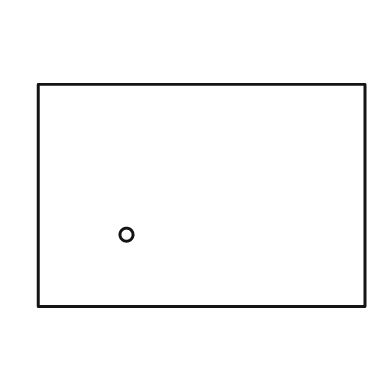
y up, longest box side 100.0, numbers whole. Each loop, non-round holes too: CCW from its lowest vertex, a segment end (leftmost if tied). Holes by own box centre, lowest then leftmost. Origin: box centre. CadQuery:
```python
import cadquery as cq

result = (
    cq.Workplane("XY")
    .moveTo(-50.0, -34.0)
    .lineTo(50.0, -34.0)
    .lineTo(50.0, 34.0)
    .lineTo(-50.0, 34.0)
    .close()
    .moveTo(-23.0, -12.0)
    .circle(2.0)
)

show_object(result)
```